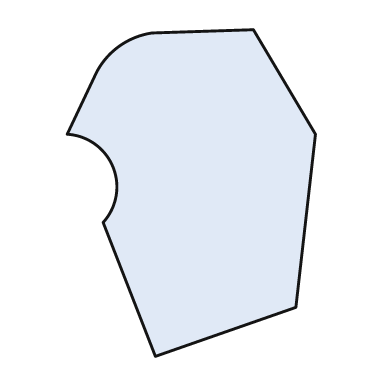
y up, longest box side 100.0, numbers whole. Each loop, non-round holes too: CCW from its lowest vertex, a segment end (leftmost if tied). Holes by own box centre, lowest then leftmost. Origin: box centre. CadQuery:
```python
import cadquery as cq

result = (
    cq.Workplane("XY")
    .moveTo(-11.0, -50.0)
    .lineTo(32.0, -35.0)
    .lineTo(38.0, 18.0)
    .lineTo(19.0, 50.0)
    .lineTo(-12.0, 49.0)
    .threePointArc((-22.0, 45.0), (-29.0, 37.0))
    .lineTo(-38.0, 18.0)
    .threePointArc((-24.0, 8.0), (-27.0, -9.0))
    .close()
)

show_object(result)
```